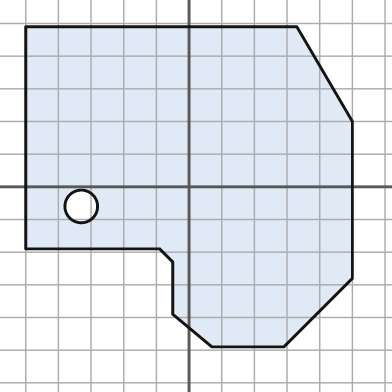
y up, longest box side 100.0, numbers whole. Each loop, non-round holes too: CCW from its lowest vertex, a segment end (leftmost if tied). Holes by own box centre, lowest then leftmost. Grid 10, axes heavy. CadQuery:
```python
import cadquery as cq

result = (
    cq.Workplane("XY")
    .moveTo(7.0, -49.0)
    .lineTo(29.0, -49.0)
    .lineTo(50.0, -28.0)
    .lineTo(50.0, 20.0)
    .lineTo(33.0, 49.0)
    .lineTo(-50.0, 49.0)
    .lineTo(-50.0, -19.0)
    .lineTo(-9.0, -19.0)
    .lineTo(-5.0, -23.0)
    .lineTo(-5.0, -39.0)
    .close()
    .moveTo(-33.0, -6.0)
    .circle(5.0)
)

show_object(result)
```